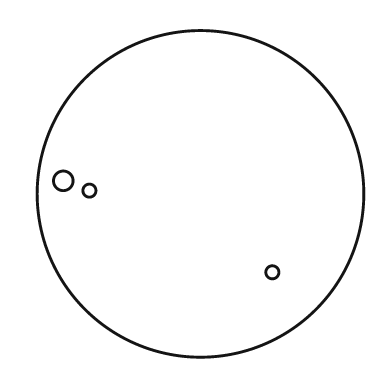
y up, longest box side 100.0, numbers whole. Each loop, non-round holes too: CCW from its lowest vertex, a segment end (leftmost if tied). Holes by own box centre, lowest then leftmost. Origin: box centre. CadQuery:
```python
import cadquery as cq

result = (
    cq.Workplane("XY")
    .moveTo(0.0, 0.0)
    .circle(50.0)
    .moveTo(22.0, -24.0)
    .circle(2.0)
    .moveTo(-34.0, 1.0)
    .circle(2.0)
    .moveTo(-42.0, 4.0)
    .circle(3.0)
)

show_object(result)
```